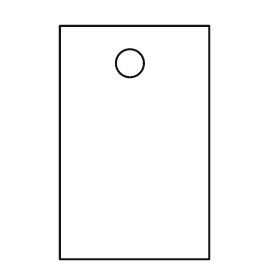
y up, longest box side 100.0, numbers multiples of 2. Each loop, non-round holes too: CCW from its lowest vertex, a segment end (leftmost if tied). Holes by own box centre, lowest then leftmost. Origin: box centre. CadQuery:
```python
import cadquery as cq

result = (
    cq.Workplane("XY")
    .moveTo(-32.0, -50.0)
    .lineTo(32.0, -50.0)
    .lineTo(32.0, 50.0)
    .lineTo(-32.0, 50.0)
    .close()
    .moveTo(-2.0, 34.0)
    .circle(6.0)
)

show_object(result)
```